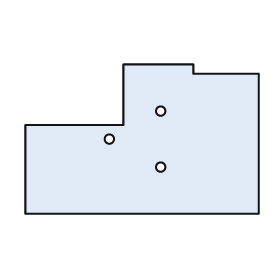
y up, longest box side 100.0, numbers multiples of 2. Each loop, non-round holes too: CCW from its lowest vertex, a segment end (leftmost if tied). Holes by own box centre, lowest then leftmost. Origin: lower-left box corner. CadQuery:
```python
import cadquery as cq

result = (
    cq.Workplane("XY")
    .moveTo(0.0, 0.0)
    .lineTo(100.0, 0.0)
    .lineTo(100.0, 60.0)
    .lineTo(72.0, 60.0)
    .lineTo(72.0, 64.0)
    .lineTo(42.0, 64.0)
    .lineTo(42.0, 38.0)
    .lineTo(0.0, 38.0)
    .close()
    .moveTo(58.0, 20.0)
    .circle(2.0)
    .moveTo(36.0, 32.0)
    .circle(2.0)
    .moveTo(58.0, 44.0)
    .circle(2.0)
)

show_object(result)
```